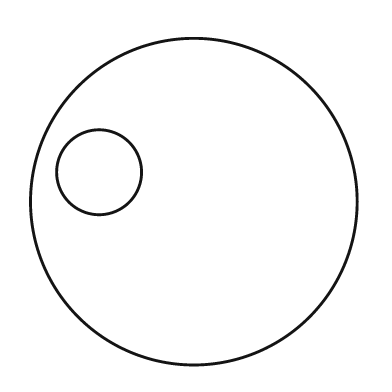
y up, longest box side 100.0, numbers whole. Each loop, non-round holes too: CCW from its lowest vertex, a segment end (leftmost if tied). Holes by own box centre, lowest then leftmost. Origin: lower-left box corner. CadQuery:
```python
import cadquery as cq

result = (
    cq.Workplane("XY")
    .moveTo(50.0, 50.0)
    .circle(50.0)
    .moveTo(21.0, 59.0)
    .circle(13.0)
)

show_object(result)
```